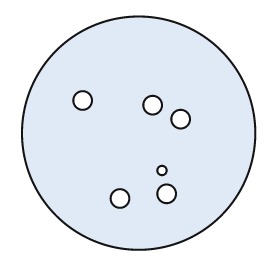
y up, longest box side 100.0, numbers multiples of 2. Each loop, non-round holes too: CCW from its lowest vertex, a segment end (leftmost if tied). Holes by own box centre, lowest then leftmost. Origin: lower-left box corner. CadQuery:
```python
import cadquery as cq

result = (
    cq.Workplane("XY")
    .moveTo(50.0, 50.0)
    .circle(50.0)
    .moveTo(42.0, 22.0)
    .circle(4.0)
    .moveTo(62.0, 24.0)
    .circle(4.0)
    .moveTo(60.0, 34.0)
    .circle(2.0)
    .moveTo(68.0, 56.0)
    .circle(4.0)
    .moveTo(56.0, 62.0)
    .circle(4.0)
    .moveTo(26.0, 64.0)
    .circle(4.0)
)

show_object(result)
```